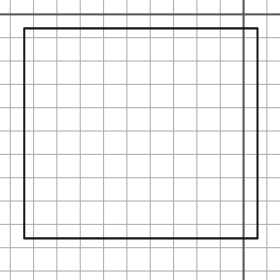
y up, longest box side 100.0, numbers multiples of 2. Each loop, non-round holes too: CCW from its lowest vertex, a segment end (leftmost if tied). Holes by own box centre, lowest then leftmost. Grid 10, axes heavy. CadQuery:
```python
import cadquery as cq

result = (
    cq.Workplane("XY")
    .moveTo(-94.0, -96.0)
    .lineTo(6.0, -96.0)
    .lineTo(6.0, -6.0)
    .lineTo(-94.0, -6.0)
    .close()
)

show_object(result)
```